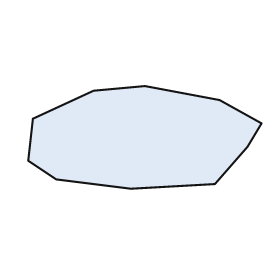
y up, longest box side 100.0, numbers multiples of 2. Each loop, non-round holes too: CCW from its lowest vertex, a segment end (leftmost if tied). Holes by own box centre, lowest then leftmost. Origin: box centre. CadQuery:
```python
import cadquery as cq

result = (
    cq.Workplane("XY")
    .moveTo(-6.0, -22.0)
    .lineTo(30.0, -20.0)
    .lineTo(44.0, -4.0)
    .lineTo(50.0, 6.0)
    .lineTo(32.0, 16.0)
    .lineTo(0.0, 22.0)
    .lineTo(-22.0, 20.0)
    .lineTo(-48.0, 8.0)
    .lineTo(-50.0, -10.0)
    .lineTo(-38.0, -18.0)
    .close()
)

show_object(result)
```